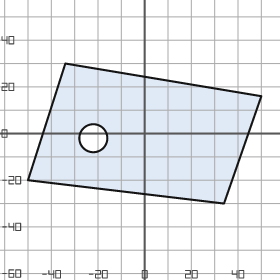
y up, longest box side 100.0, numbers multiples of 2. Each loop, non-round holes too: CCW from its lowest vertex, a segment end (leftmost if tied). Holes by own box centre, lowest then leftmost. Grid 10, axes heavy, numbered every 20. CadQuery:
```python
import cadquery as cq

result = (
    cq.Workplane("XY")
    .moveTo(34.0, -30.0)
    .lineTo(50.0, 16.0)
    .lineTo(-34.0, 30.0)
    .lineTo(-50.0, -20.0)
    .close()
    .moveTo(-22.0, -2.0)
    .circle(6.0)
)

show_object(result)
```